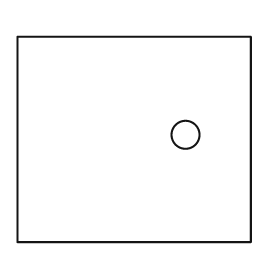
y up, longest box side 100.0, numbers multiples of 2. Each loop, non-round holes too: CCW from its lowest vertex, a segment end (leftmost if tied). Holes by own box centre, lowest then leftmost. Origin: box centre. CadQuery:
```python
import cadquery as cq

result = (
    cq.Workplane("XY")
    .moveTo(-50.0, -44.0)
    .lineTo(50.0, -44.0)
    .lineTo(50.0, 44.0)
    .lineTo(-50.0, 44.0)
    .close()
    .moveTo(22.0, 2.0)
    .circle(6.0)
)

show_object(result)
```